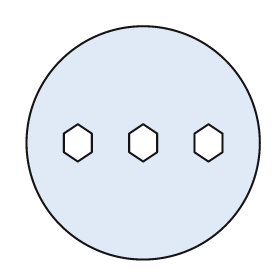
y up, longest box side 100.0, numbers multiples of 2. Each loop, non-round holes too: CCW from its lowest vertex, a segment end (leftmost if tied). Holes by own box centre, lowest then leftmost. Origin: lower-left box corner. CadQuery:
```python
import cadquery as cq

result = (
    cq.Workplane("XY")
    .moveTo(50.0, 50.0)
    .circle(50.0)
    .moveTo(22.0, 42.0)
    .lineTo(28.0, 46.0)
    .lineTo(28.0, 54.0)
    .lineTo(22.0, 58.0)
    .lineTo(16.0, 54.0)
    .lineTo(16.0, 46.0)
    .close()
    .moveTo(50.0, 42.0)
    .lineTo(56.0, 46.0)
    .lineTo(56.0, 54.0)
    .lineTo(50.0, 58.0)
    .lineTo(44.0, 54.0)
    .lineTo(44.0, 46.0)
    .close()
    .moveTo(78.0, 42.0)
    .lineTo(84.0, 46.0)
    .lineTo(84.0, 54.0)
    .lineTo(78.0, 58.0)
    .lineTo(72.0, 54.0)
    .lineTo(72.0, 46.0)
    .close()
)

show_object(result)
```